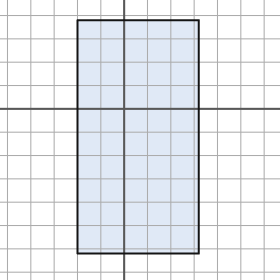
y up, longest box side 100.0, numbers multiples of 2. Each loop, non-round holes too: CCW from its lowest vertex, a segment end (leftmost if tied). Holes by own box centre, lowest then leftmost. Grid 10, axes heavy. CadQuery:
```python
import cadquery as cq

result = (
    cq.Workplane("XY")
    .moveTo(-20.0, -62.0)
    .lineTo(32.0, -62.0)
    .lineTo(32.0, 38.0)
    .lineTo(-20.0, 38.0)
    .close()
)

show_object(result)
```